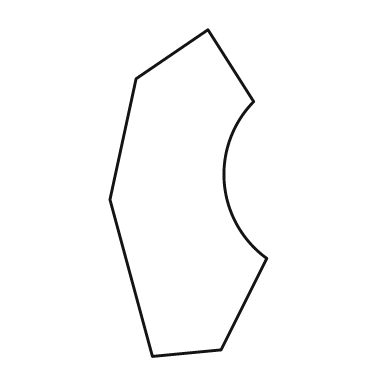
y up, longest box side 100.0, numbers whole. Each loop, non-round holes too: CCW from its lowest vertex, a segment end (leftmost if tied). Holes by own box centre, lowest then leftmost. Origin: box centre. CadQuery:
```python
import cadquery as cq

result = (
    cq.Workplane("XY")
    .moveTo(-11.0, -50.0)
    .lineTo(10.0, -48.0)
    .lineTo(24.0, -20.0)
    .threePointArc((11.0, 3.0), (20.0, 28.0))
    .lineTo(6.0, 50.0)
    .lineTo(-16.0, 35.0)
    .lineTo(-24.0, -2.0)
    .close()
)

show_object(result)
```